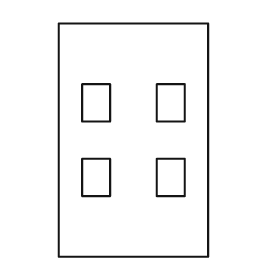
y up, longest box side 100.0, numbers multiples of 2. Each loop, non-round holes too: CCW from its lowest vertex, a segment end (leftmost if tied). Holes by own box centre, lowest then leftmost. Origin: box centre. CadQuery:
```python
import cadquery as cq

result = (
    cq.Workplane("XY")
    .moveTo(-32.0, -50.0)
    .lineTo(32.0, -50.0)
    .lineTo(32.0, 50.0)
    .lineTo(-32.0, 50.0)
    .close()
    .moveTo(-22.0, -24.0)
    .lineTo(-10.0, -24.0)
    .lineTo(-10.0, -8.0)
    .lineTo(-22.0, -8.0)
    .close()
    .moveTo(10.0, -24.0)
    .lineTo(22.0, -24.0)
    .lineTo(22.0, -8.0)
    .lineTo(10.0, -8.0)
    .close()
    .moveTo(-22.0, 8.0)
    .lineTo(-10.0, 8.0)
    .lineTo(-10.0, 24.0)
    .lineTo(-22.0, 24.0)
    .close()
    .moveTo(10.0, 8.0)
    .lineTo(22.0, 8.0)
    .lineTo(22.0, 24.0)
    .lineTo(10.0, 24.0)
    .close()
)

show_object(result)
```